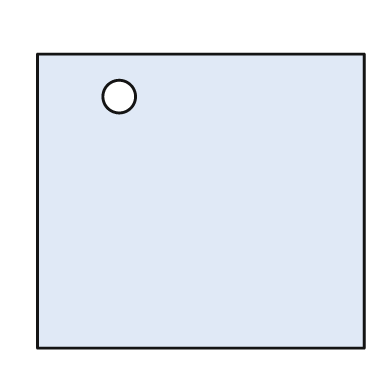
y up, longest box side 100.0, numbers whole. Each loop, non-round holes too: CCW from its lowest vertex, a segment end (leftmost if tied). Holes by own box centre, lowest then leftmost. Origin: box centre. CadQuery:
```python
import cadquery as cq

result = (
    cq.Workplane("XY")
    .moveTo(-50.0, -45.0)
    .lineTo(50.0, -45.0)
    .lineTo(50.0, 45.0)
    .lineTo(-50.0, 45.0)
    .close()
    .moveTo(-25.0, 32.0)
    .circle(5.0)
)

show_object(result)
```